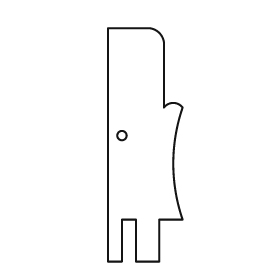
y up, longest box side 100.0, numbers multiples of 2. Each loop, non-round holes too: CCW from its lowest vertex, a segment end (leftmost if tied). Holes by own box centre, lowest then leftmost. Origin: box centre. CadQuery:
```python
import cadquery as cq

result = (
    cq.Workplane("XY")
    .moveTo(-16.0, -50.0)
    .lineTo(-10.0, -50.0)
    .lineTo(-10.0, -32.0)
    .lineTo(-4.0, -32.0)
    .lineTo(-4.0, -50.0)
    .lineTo(6.0, -50.0)
    .lineTo(6.0, -32.0)
    .lineTo(16.0, -32.0)
    .threePointArc((12.0, -8.0), (16.0, 16.0))
    .threePointArc((12.0, 18.0), (8.0, 16.0))
    .lineTo(8.0, 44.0)
    .threePointArc((6.0, 48.0), (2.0, 50.0))
    .lineTo(-16.0, 50.0)
    .close()
    .moveTo(-10.0, 4.0)
    .circle(2.0)
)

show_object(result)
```